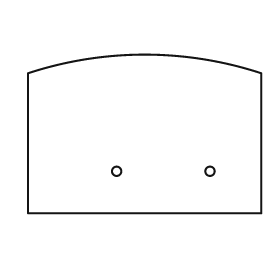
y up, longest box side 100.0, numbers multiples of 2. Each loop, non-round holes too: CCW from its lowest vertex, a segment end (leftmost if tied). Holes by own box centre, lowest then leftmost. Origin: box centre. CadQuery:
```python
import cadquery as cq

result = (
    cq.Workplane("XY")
    .moveTo(-50.0, -34.0)
    .lineTo(50.0, -34.0)
    .lineTo(50.0, 26.0)
    .threePointArc((0.0, 34.0), (-50.0, 26.0))
    .close()
    .moveTo(-12.0, -16.0)
    .circle(2.0)
    .moveTo(28.0, -16.0)
    .circle(2.0)
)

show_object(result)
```